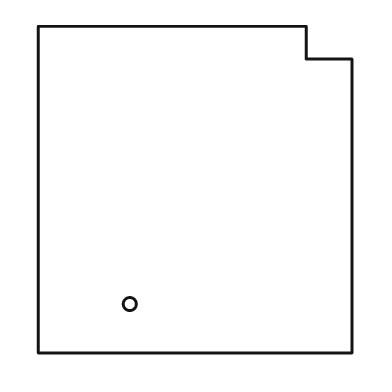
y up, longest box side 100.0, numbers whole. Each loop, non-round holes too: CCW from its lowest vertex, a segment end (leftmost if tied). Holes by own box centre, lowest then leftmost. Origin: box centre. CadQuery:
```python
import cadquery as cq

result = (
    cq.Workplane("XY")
    .moveTo(-48.0, -50.0)
    .lineTo(48.0, -50.0)
    .lineTo(48.0, 40.0)
    .lineTo(34.0, 40.0)
    .lineTo(34.0, 50.0)
    .lineTo(-48.0, 50.0)
    .close()
    .moveTo(-20.0, -35.0)
    .circle(2.0)
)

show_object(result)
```